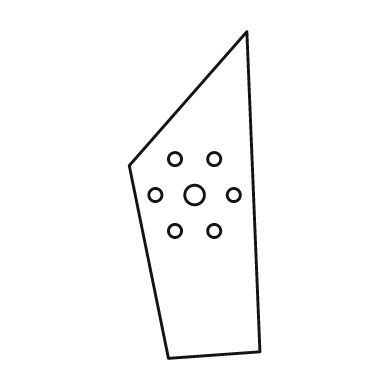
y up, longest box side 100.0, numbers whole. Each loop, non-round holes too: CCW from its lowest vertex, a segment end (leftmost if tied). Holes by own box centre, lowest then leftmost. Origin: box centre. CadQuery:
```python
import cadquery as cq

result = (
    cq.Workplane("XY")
    .moveTo(-8.0, -50.0)
    .lineTo(20.0, -48.0)
    .lineTo(16.0, 50.0)
    .lineTo(-20.0, 9.0)
    .close()
    .moveTo(-6.0, -11.0)
    .circle(2.0)
    .moveTo(6.0, -11.0)
    .circle(2.0)
    .moveTo(-12.0, 0.0)
    .circle(2.0)
    .moveTo(0.0, 0.0)
    .circle(3.0)
    .moveTo(12.0, 0.0)
    .circle(2.0)
    .moveTo(-6.0, 11.0)
    .circle(2.0)
    .moveTo(6.0, 11.0)
    .circle(2.0)
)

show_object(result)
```